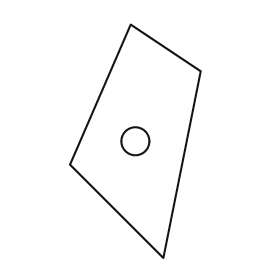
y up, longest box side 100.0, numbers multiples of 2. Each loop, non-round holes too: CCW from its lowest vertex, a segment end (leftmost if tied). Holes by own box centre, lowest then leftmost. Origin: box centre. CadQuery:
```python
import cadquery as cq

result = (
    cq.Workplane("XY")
    .moveTo(12.0, -50.0)
    .lineTo(28.0, 30.0)
    .lineTo(-2.0, 50.0)
    .lineTo(-28.0, -10.0)
    .close()
    .moveTo(0.0, 0.0)
    .circle(6.0)
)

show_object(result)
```